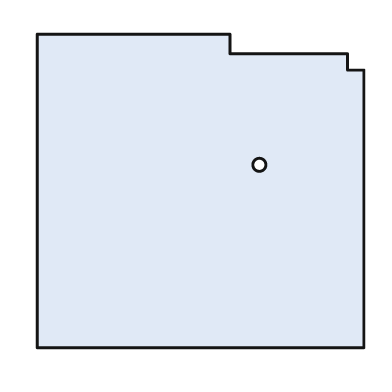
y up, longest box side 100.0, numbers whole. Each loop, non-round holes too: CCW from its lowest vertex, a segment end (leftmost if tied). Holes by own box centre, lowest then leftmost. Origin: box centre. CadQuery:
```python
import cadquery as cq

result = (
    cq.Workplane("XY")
    .moveTo(-50.0, -48.0)
    .lineTo(50.0, -48.0)
    .lineTo(50.0, 37.0)
    .lineTo(45.0, 37.0)
    .lineTo(45.0, 42.0)
    .lineTo(9.0, 42.0)
    .lineTo(9.0, 48.0)
    .lineTo(-50.0, 48.0)
    .close()
    .moveTo(18.0, 8.0)
    .circle(2.0)
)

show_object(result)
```